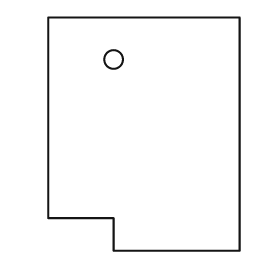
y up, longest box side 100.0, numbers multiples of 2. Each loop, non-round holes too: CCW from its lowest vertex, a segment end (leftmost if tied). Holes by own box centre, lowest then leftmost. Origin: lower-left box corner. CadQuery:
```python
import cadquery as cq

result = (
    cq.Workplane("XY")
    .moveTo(28.0, 0.0)
    .lineTo(82.0, 0.0)
    .lineTo(82.0, 100.0)
    .lineTo(0.0, 100.0)
    .lineTo(0.0, 14.0)
    .lineTo(28.0, 14.0)
    .close()
    .moveTo(28.0, 82.0)
    .circle(4.0)
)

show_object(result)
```